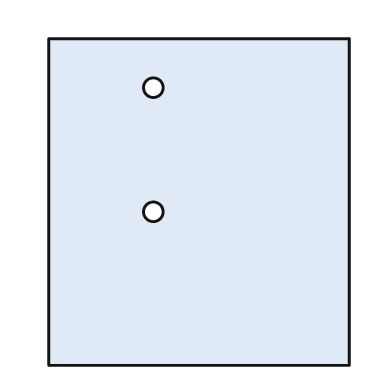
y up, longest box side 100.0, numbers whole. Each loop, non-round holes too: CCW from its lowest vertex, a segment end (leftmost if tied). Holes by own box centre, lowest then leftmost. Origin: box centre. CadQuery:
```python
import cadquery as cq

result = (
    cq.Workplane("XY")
    .moveTo(-46.0, -50.0)
    .lineTo(46.0, -50.0)
    .lineTo(46.0, 50.0)
    .lineTo(-46.0, 50.0)
    .close()
    .moveTo(-14.0, -3.0)
    .circle(3.0)
    .moveTo(-14.0, 35.0)
    .circle(3.0)
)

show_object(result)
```